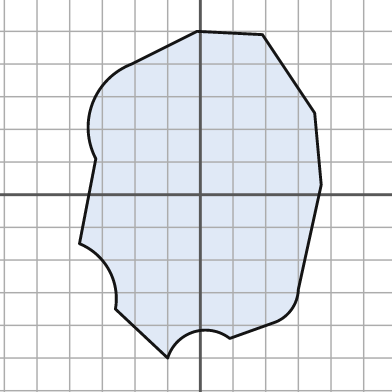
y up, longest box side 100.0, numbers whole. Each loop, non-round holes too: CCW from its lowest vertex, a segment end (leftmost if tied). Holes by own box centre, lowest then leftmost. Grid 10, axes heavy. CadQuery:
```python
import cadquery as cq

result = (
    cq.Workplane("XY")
    .moveTo(-10.0, -50.0)
    .threePointArc((-2.0, -42.0), (9.0, -44.0))
    .lineTo(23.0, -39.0)
    .threePointArc((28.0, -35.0), (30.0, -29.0))
    .lineTo(37.0, 3.0)
    .lineTo(35.0, 25.0)
    .lineTo(19.0, 49.0)
    .lineTo(-1.0, 50.0)
    .lineTo(-21.0, 40.0)
    .threePointArc((-33.0, 28.0), (-32.0, 11.0))
    .lineTo(-37.0, -15.0)
    .threePointArc((-28.0, -23.0), (-26.0, -35.0))
    .close()
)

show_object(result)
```